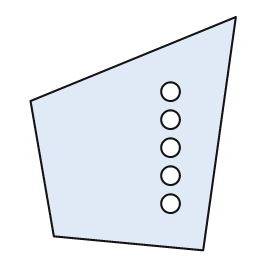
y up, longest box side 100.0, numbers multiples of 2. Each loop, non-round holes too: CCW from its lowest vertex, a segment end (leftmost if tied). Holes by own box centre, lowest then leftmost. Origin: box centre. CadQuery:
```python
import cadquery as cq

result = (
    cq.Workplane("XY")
    .moveTo(30.0, -50.0)
    .lineTo(44.0, 50.0)
    .lineTo(-44.0, 14.0)
    .lineTo(-34.0, -44.0)
    .close()
    .moveTo(16.0, -30.0)
    .circle(4.0)
    .moveTo(16.0, -18.0)
    .circle(4.0)
    .moveTo(16.0, -6.0)
    .circle(4.0)
    .moveTo(16.0, 6.0)
    .circle(4.0)
    .moveTo(16.0, 18.0)
    .circle(4.0)
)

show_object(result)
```